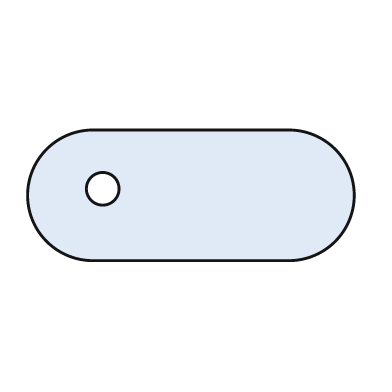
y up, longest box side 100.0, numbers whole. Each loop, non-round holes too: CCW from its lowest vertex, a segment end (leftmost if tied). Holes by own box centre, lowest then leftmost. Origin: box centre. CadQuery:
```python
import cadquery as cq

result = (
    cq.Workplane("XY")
    .moveTo(-30.0, -20.0)
    .lineTo(30.0, -20.0)
    .threePointArc((50.0, 0.0), (30.0, 20.0))
    .lineTo(-30.0, 20.0)
    .threePointArc((-50.0, 0.0), (-30.0, -20.0))
    .close()
    .moveTo(-27.0, 2.0)
    .circle(5.0)
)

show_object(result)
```